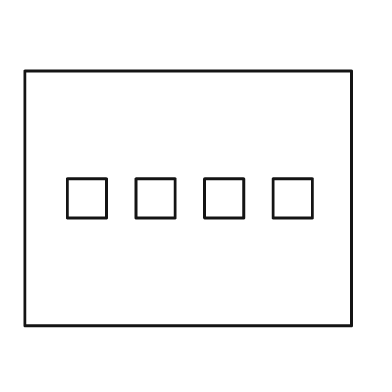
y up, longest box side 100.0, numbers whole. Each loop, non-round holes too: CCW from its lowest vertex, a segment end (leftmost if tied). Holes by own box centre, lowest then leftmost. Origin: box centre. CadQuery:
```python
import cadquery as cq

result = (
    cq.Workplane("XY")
    .moveTo(-50.0, -39.0)
    .lineTo(50.0, -39.0)
    .lineTo(50.0, 39.0)
    .lineTo(-50.0, 39.0)
    .close()
    .moveTo(-37.0, -6.0)
    .lineTo(-25.0, -6.0)
    .lineTo(-25.0, 6.0)
    .lineTo(-37.0, 6.0)
    .close()
    .moveTo(-16.0, -6.0)
    .lineTo(-4.0, -6.0)
    .lineTo(-4.0, 6.0)
    .lineTo(-16.0, 6.0)
    .close()
    .moveTo(5.0, -6.0)
    .lineTo(17.0, -6.0)
    .lineTo(17.0, 6.0)
    .lineTo(5.0, 6.0)
    .close()
    .moveTo(26.0, -6.0)
    .lineTo(38.0, -6.0)
    .lineTo(38.0, 6.0)
    .lineTo(26.0, 6.0)
    .close()
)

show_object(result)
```